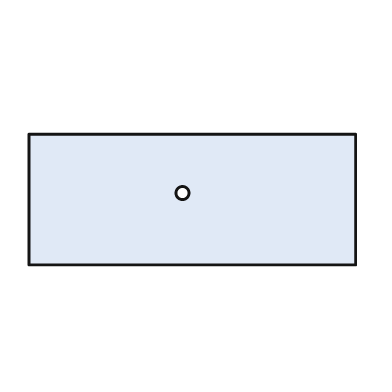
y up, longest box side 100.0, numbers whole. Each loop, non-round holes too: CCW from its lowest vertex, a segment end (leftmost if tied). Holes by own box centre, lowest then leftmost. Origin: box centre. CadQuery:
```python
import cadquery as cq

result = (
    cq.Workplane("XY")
    .moveTo(-50.0, -20.0)
    .lineTo(50.0, -20.0)
    .lineTo(50.0, 20.0)
    .lineTo(-50.0, 20.0)
    .close()
    .moveTo(-3.0, 2.0)
    .circle(2.0)
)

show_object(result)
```